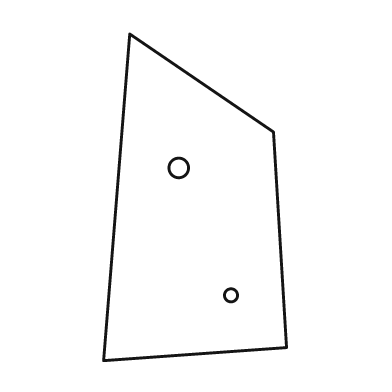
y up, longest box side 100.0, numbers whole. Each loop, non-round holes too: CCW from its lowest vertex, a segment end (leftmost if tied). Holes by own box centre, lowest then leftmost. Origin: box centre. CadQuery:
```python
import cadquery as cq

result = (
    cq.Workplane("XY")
    .moveTo(-28.0, -50.0)
    .lineTo(28.0, -46.0)
    .lineTo(24.0, 20.0)
    .lineTo(-20.0, 50.0)
    .close()
    .moveTo(11.0, -30.0)
    .circle(2.0)
    .moveTo(-5.0, 9.0)
    .circle(3.0)
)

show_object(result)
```